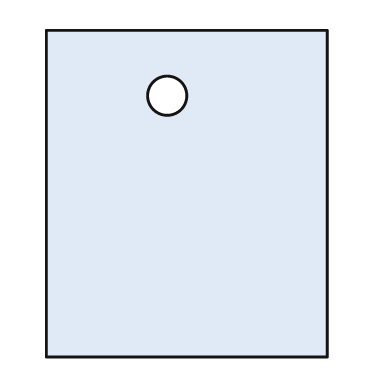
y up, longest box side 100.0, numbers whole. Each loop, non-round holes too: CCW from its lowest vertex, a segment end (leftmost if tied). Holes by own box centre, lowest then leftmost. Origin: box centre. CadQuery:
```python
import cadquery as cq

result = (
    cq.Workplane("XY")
    .moveTo(-43.0, -50.0)
    .lineTo(43.0, -50.0)
    .lineTo(43.0, 50.0)
    .lineTo(-43.0, 50.0)
    .close()
    .moveTo(-6.0, 30.0)
    .circle(6.0)
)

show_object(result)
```